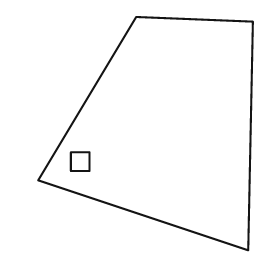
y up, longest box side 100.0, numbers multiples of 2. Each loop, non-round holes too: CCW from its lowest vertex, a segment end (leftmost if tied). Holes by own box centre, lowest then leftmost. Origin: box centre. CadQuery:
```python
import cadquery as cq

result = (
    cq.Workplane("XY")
    .moveTo(44.0, -50.0)
    .lineTo(46.0, 48.0)
    .lineTo(-4.0, 50.0)
    .lineTo(-46.0, -20.0)
    .close()
    .moveTo(-32.0, -16.0)
    .lineTo(-24.0, -16.0)
    .lineTo(-24.0, -8.0)
    .lineTo(-32.0, -8.0)
    .close()
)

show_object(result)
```